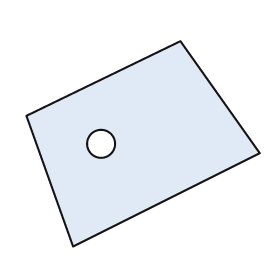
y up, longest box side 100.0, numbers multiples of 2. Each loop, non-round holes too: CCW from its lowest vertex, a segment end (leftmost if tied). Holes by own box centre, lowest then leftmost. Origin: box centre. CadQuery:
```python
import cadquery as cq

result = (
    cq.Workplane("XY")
    .moveTo(-30.0, -44.0)
    .lineTo(50.0, -4.0)
    .lineTo(16.0, 44.0)
    .lineTo(-50.0, 12.0)
    .close()
    .moveTo(-18.0, 0.0)
    .circle(6.0)
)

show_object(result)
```